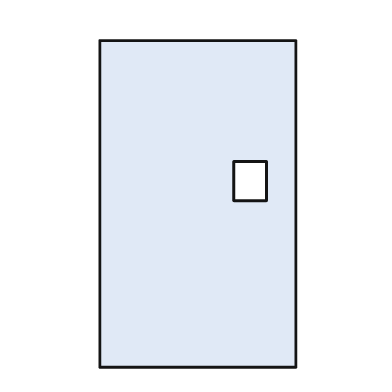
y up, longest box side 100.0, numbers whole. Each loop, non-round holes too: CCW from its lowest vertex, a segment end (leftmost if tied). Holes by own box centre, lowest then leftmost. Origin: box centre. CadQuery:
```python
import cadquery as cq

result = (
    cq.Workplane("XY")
    .moveTo(-30.0, -50.0)
    .lineTo(30.0, -50.0)
    .lineTo(30.0, 50.0)
    .lineTo(-30.0, 50.0)
    .close()
    .moveTo(11.0, 1.0)
    .lineTo(21.0, 1.0)
    .lineTo(21.0, 13.0)
    .lineTo(11.0, 13.0)
    .close()
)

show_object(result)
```